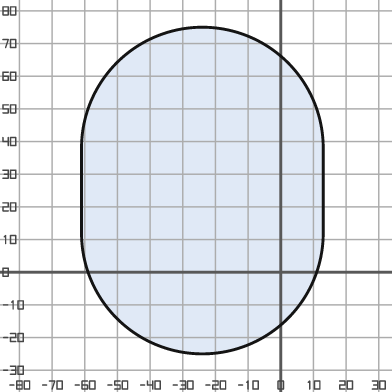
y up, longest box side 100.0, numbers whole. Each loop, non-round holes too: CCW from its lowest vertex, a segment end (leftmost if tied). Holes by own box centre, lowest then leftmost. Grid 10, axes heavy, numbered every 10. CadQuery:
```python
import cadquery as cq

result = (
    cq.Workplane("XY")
    .moveTo(-61.0, 12.0)
    .threePointArc((-24.0, -25.0), (13.0, 12.0))
    .lineTo(13.0, 38.0)
    .threePointArc((-24.0, 75.0), (-61.0, 38.0))
    .close()
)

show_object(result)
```